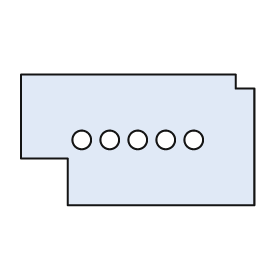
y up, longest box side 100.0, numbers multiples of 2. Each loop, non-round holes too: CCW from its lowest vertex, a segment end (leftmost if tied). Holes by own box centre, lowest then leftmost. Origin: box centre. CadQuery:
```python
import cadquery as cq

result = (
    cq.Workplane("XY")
    .moveTo(-30.0, -28.0)
    .lineTo(50.0, -28.0)
    .lineTo(50.0, 22.0)
    .lineTo(42.0, 22.0)
    .lineTo(42.0, 28.0)
    .lineTo(-50.0, 28.0)
    .lineTo(-50.0, -8.0)
    .lineTo(-30.0, -8.0)
    .close()
    .moveTo(-24.0, 0.0)
    .circle(4.0)
    .moveTo(-12.0, 0.0)
    .circle(4.0)
    .moveTo(0.0, 0.0)
    .circle(4.0)
    .moveTo(12.0, 0.0)
    .circle(4.0)
    .moveTo(24.0, 0.0)
    .circle(4.0)
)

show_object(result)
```